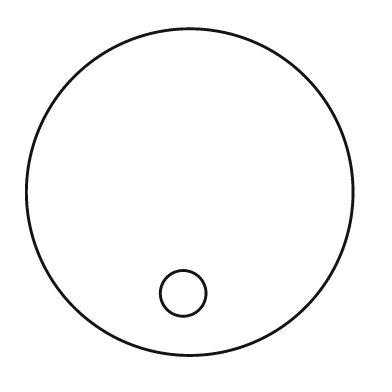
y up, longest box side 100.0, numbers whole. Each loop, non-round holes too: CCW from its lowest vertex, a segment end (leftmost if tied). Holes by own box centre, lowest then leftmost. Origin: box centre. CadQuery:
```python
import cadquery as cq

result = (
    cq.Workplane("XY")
    .moveTo(0.0, 0.0)
    .circle(50.0)
    .moveTo(-2.0, -31.0)
    .circle(7.0)
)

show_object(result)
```